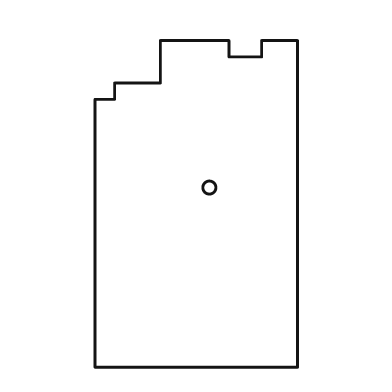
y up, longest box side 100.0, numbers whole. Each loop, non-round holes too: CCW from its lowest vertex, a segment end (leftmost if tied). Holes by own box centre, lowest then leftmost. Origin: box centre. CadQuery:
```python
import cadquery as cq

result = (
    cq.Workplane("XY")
    .moveTo(-31.0, -50.0)
    .lineTo(31.0, -50.0)
    .lineTo(31.0, 50.0)
    .lineTo(20.0, 50.0)
    .lineTo(20.0, 45.0)
    .lineTo(10.0, 45.0)
    .lineTo(10.0, 50.0)
    .lineTo(-11.0, 50.0)
    .lineTo(-11.0, 37.0)
    .lineTo(-25.0, 37.0)
    .lineTo(-25.0, 32.0)
    .lineTo(-31.0, 32.0)
    .close()
    .moveTo(4.0, 5.0)
    .circle(2.0)
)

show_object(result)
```